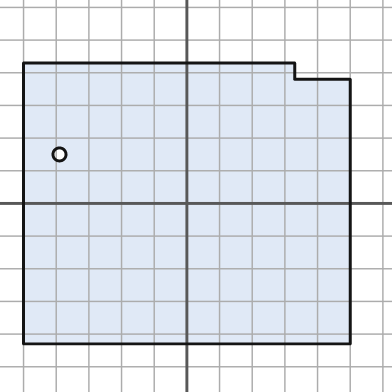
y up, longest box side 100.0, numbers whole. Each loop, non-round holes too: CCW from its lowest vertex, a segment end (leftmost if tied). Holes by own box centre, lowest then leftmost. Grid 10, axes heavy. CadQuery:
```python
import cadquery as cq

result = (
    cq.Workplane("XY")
    .moveTo(-50.0, -43.0)
    .lineTo(50.0, -43.0)
    .lineTo(50.0, 38.0)
    .lineTo(33.0, 38.0)
    .lineTo(33.0, 43.0)
    .lineTo(-50.0, 43.0)
    .close()
    .moveTo(-39.0, 15.0)
    .circle(2.0)
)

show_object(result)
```